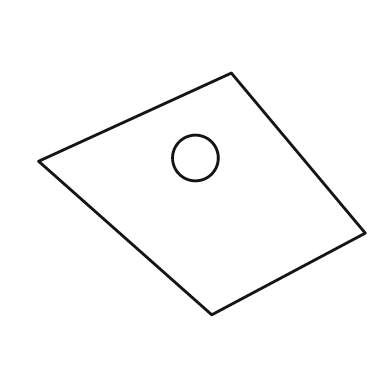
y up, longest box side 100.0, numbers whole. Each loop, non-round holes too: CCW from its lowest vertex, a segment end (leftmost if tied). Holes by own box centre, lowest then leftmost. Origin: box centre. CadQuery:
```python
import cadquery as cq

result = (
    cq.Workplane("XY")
    .moveTo(3.0, -37.0)
    .lineTo(50.0, -12.0)
    .lineTo(9.0, 37.0)
    .lineTo(-50.0, 10.0)
    .close()
    .moveTo(-2.0, 11.0)
    .circle(7.0)
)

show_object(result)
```